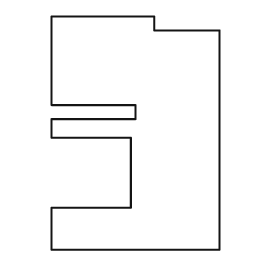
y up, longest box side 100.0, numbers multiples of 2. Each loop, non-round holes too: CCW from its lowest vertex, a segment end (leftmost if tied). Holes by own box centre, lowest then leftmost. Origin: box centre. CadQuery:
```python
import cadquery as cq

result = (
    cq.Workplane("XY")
    .moveTo(-36.0, -50.0)
    .lineTo(36.0, -50.0)
    .lineTo(36.0, 44.0)
    .lineTo(8.0, 44.0)
    .lineTo(8.0, 50.0)
    .lineTo(-36.0, 50.0)
    .lineTo(-36.0, 12.0)
    .lineTo(0.0, 12.0)
    .lineTo(0.0, 6.0)
    .lineTo(-36.0, 6.0)
    .lineTo(-36.0, -2.0)
    .lineTo(-2.0, -2.0)
    .lineTo(-2.0, -32.0)
    .lineTo(-36.0, -32.0)
    .close()
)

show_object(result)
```